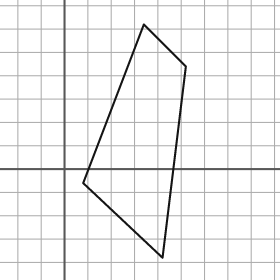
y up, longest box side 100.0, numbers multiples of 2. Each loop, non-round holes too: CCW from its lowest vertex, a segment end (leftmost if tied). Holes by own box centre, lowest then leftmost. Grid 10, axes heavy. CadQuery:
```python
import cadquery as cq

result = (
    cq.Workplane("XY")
    .moveTo(42.0, -38.0)
    .lineTo(52.0, 44.0)
    .lineTo(34.0, 62.0)
    .lineTo(8.0, -6.0)
    .close()
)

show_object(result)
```